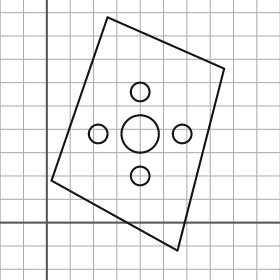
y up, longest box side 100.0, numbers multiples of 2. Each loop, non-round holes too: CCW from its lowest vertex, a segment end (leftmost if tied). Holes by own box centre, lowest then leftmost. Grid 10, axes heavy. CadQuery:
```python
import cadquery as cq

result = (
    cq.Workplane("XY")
    .moveTo(56.0, -12.0)
    .lineTo(76.0, 66.0)
    .lineTo(26.0, 88.0)
    .lineTo(2.0, 18.0)
    .close()
    .moveTo(40.0, 20.0)
    .circle(4.0)
    .moveTo(22.0, 38.0)
    .circle(4.0)
    .moveTo(40.0, 38.0)
    .circle(8.0)
    .moveTo(58.0, 38.0)
    .circle(4.0)
    .moveTo(40.0, 56.0)
    .circle(4.0)
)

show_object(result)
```